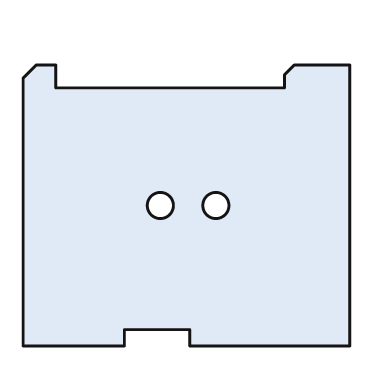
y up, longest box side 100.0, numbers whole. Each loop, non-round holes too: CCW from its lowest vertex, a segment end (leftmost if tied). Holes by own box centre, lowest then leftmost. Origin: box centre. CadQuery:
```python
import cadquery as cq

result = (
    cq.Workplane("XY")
    .moveTo(-50.0, -43.0)
    .lineTo(-19.0, -43.0)
    .lineTo(-19.0, -38.0)
    .lineTo(1.0, -38.0)
    .lineTo(1.0, -43.0)
    .lineTo(50.0, -43.0)
    .lineTo(50.0, 43.0)
    .lineTo(33.0, 43.0)
    .lineTo(30.0, 40.0)
    .lineTo(30.0, 36.0)
    .lineTo(-40.0, 36.0)
    .lineTo(-40.0, 43.0)
    .lineTo(-46.0, 43.0)
    .lineTo(-50.0, 39.0)
    .close()
    .moveTo(-8.0, 0.0)
    .circle(4.0)
    .moveTo(9.0, 0.0)
    .circle(4.0)
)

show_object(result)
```